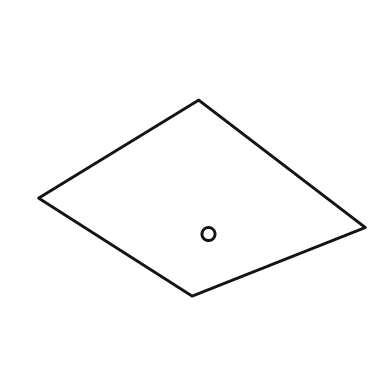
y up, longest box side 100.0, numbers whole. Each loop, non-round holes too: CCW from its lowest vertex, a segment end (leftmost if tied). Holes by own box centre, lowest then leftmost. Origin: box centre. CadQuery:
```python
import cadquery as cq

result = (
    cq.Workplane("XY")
    .moveTo(-3.0, -30.0)
    .lineTo(50.0, -9.0)
    .lineTo(-1.0, 30.0)
    .lineTo(-50.0, 0.0)
    .close()
    .moveTo(2.0, -11.0)
    .circle(2.0)
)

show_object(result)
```